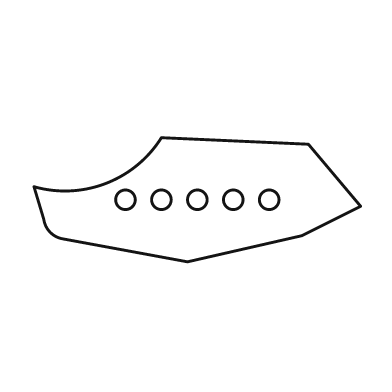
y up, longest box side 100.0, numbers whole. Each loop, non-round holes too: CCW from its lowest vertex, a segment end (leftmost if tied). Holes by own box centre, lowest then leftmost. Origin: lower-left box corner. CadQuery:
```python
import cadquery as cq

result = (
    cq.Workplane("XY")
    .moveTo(47.0, 0.0)
    .lineTo(82.0, 8.0)
    .lineTo(100.0, 17.0)
    .lineTo(84.0, 36.0)
    .lineTo(39.0, 38.0)
    .threePointArc((22.0, 24.0), (0.0, 23.0))
    .lineTo(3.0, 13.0)
    .threePointArc((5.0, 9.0), (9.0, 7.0))
    .close()
    .moveTo(28.0, 19.0)
    .circle(3.0)
    .moveTo(39.0, 19.0)
    .circle(3.0)
    .moveTo(50.0, 19.0)
    .circle(3.0)
    .moveTo(61.0, 19.0)
    .circle(3.0)
    .moveTo(72.0, 19.0)
    .circle(3.0)
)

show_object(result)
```